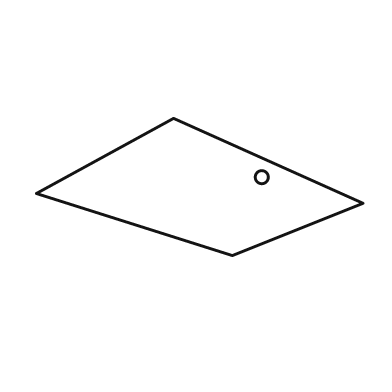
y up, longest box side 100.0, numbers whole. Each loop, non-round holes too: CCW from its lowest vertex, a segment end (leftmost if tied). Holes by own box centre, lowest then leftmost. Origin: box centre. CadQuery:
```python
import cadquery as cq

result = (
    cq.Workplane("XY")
    .moveTo(10.0, -21.0)
    .lineTo(50.0, -5.0)
    .lineTo(-8.0, 21.0)
    .lineTo(-50.0, -2.0)
    .close()
    .moveTo(19.0, 3.0)
    .circle(2.0)
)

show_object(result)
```